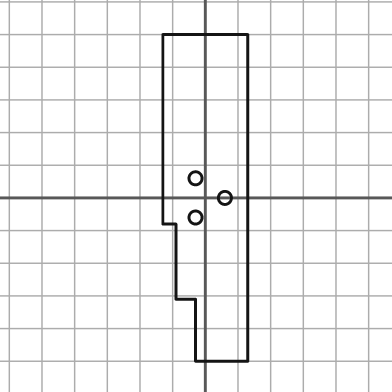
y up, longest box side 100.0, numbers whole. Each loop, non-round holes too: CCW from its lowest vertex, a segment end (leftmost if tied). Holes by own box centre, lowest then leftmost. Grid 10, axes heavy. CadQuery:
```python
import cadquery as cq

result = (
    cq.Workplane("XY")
    .moveTo(-3.0, -50.0)
    .lineTo(13.0, -50.0)
    .lineTo(13.0, 50.0)
    .lineTo(-13.0, 50.0)
    .lineTo(-13.0, -8.0)
    .lineTo(-9.0, -8.0)
    .lineTo(-9.0, -31.0)
    .lineTo(-3.0, -31.0)
    .close()
    .moveTo(-3.0, -6.0)
    .circle(2.0)
    .moveTo(6.0, 0.0)
    .circle(2.0)
    .moveTo(-3.0, 6.0)
    .circle(2.0)
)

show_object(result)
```